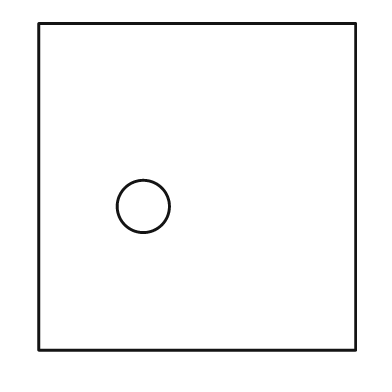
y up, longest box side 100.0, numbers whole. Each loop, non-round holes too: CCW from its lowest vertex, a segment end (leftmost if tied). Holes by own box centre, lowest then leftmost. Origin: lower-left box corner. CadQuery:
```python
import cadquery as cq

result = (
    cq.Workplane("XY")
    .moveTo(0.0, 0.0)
    .lineTo(97.0, 0.0)
    .lineTo(97.0, 100.0)
    .lineTo(0.0, 100.0)
    .close()
    .moveTo(32.0, 44.0)
    .circle(8.0)
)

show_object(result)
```